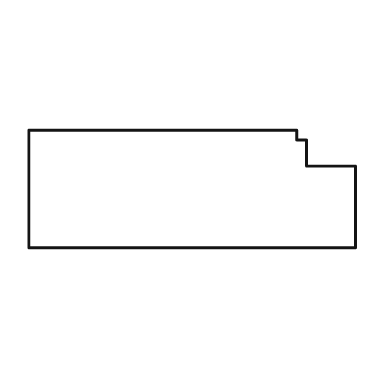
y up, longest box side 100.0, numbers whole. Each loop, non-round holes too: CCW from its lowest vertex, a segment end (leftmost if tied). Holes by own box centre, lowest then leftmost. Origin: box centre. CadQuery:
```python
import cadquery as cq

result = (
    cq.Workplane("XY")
    .moveTo(-50.0, -18.0)
    .lineTo(50.0, -18.0)
    .lineTo(50.0, 7.0)
    .lineTo(35.0, 7.0)
    .lineTo(35.0, 15.0)
    .lineTo(32.0, 15.0)
    .lineTo(32.0, 18.0)
    .lineTo(-50.0, 18.0)
    .close()
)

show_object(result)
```